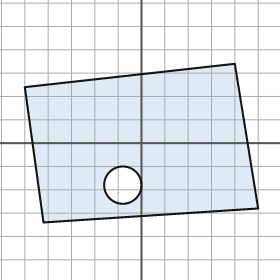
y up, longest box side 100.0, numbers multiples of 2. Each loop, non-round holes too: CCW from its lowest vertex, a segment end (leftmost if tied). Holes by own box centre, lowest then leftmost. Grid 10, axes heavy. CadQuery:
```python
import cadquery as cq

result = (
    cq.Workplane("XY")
    .moveTo(-42.0, -34.0)
    .lineTo(50.0, -28.0)
    .lineTo(40.0, 34.0)
    .lineTo(-50.0, 24.0)
    .close()
    .moveTo(-8.0, -18.0)
    .circle(8.0)
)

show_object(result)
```